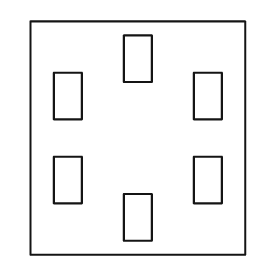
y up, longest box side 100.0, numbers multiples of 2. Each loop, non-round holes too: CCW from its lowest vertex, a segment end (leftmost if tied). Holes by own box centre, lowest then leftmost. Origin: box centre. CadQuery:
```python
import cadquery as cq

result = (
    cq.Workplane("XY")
    .moveTo(-46.0, -50.0)
    .lineTo(46.0, -50.0)
    .lineTo(46.0, 50.0)
    .lineTo(-46.0, 50.0)
    .close()
    .moveTo(-6.0, -44.0)
    .lineTo(6.0, -44.0)
    .lineTo(6.0, -24.0)
    .lineTo(-6.0, -24.0)
    .close()
    .moveTo(-36.0, -28.0)
    .lineTo(-24.0, -28.0)
    .lineTo(-24.0, -8.0)
    .lineTo(-36.0, -8.0)
    .close()
    .moveTo(24.0, -28.0)
    .lineTo(36.0, -28.0)
    .lineTo(36.0, -8.0)
    .lineTo(24.0, -8.0)
    .close()
    .moveTo(-36.0, 8.0)
    .lineTo(-24.0, 8.0)
    .lineTo(-24.0, 28.0)
    .lineTo(-36.0, 28.0)
    .close()
    .moveTo(24.0, 8.0)
    .lineTo(36.0, 8.0)
    .lineTo(36.0, 28.0)
    .lineTo(24.0, 28.0)
    .close()
    .moveTo(-6.0, 24.0)
    .lineTo(6.0, 24.0)
    .lineTo(6.0, 44.0)
    .lineTo(-6.0, 44.0)
    .close()
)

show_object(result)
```